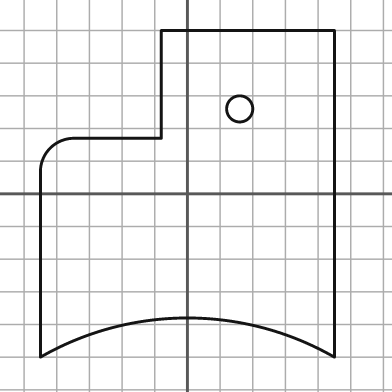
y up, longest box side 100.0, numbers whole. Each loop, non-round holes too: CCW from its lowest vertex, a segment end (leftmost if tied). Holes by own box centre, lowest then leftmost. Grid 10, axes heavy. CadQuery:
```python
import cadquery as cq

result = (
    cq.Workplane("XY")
    .moveTo(-45.0, -50.0)
    .threePointArc((0.0, -38.0), (45.0, -50.0))
    .lineTo(45.0, 50.0)
    .lineTo(-8.0, 50.0)
    .lineTo(-8.0, 17.0)
    .lineTo(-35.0, 17.0)
    .threePointArc((-42.0, 14.0), (-45.0, 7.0))
    .close()
    .moveTo(16.0, 26.0)
    .circle(4.0)
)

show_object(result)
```